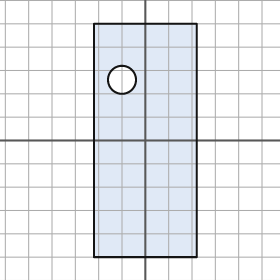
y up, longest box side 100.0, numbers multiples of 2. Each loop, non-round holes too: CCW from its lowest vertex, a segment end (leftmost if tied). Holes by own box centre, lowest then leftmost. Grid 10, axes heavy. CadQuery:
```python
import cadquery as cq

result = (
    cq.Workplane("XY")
    .moveTo(-22.0, -50.0)
    .lineTo(22.0, -50.0)
    .lineTo(22.0, 50.0)
    .lineTo(-22.0, 50.0)
    .close()
    .moveTo(-10.0, 26.0)
    .circle(6.0)
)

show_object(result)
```